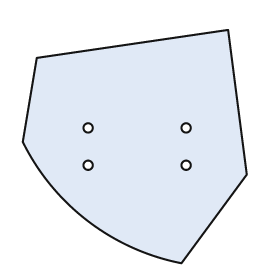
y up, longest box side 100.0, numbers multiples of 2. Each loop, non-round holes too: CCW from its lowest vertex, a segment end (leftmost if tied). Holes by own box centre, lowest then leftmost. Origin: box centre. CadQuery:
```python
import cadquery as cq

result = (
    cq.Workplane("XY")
    .moveTo(20.0, -50.0)
    .lineTo(48.0, -12.0)
    .lineTo(40.0, 50.0)
    .lineTo(-42.0, 38.0)
    .lineTo(-48.0, 2.0)
    .threePointArc((-20.0, -32.0), (20.0, -50.0))
    .close()
    .moveTo(-20.0, -8.0)
    .circle(2.0)
    .moveTo(22.0, -8.0)
    .circle(2.0)
    .moveTo(-20.0, 8.0)
    .circle(2.0)
    .moveTo(22.0, 8.0)
    .circle(2.0)
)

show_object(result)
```